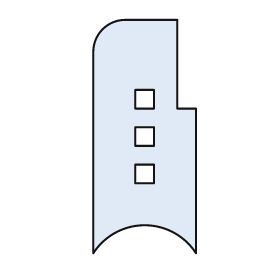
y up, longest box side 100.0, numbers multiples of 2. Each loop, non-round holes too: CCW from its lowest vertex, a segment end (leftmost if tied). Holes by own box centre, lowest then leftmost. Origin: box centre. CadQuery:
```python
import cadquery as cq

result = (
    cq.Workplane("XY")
    .moveTo(-22.0, -50.0)
    .threePointArc((0.0, -38.0), (22.0, -50.0))
    .lineTo(22.0, 12.0)
    .lineTo(14.0, 12.0)
    .lineTo(14.0, 50.0)
    .lineTo(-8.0, 50.0)
    .threePointArc((-18.0, 46.0), (-22.0, 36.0))
    .close()
    .moveTo(-4.0, -20.0)
    .lineTo(4.0, -20.0)
    .lineTo(4.0, -12.0)
    .lineTo(-4.0, -12.0)
    .close()
    .moveTo(-4.0, -4.0)
    .lineTo(4.0, -4.0)
    .lineTo(4.0, 4.0)
    .lineTo(-4.0, 4.0)
    .close()
    .moveTo(-4.0, 12.0)
    .lineTo(4.0, 12.0)
    .lineTo(4.0, 20.0)
    .lineTo(-4.0, 20.0)
    .close()
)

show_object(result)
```